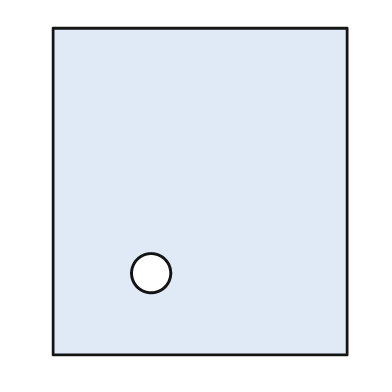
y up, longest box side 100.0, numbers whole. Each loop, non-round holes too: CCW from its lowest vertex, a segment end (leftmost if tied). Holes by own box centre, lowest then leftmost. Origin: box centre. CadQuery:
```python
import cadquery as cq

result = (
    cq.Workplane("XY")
    .moveTo(-45.0, -50.0)
    .lineTo(45.0, -50.0)
    .lineTo(45.0, 50.0)
    .lineTo(-45.0, 50.0)
    .close()
    .moveTo(-15.0, -25.0)
    .circle(6.0)
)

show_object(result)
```